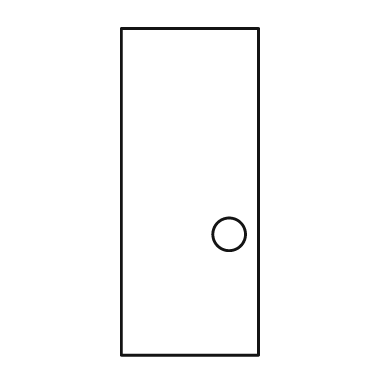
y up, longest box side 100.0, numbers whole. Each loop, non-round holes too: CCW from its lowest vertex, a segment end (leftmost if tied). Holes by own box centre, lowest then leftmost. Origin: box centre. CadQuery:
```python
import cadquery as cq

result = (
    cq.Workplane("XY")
    .moveTo(-21.0, -50.0)
    .lineTo(21.0, -50.0)
    .lineTo(21.0, 50.0)
    .lineTo(-21.0, 50.0)
    .close()
    .moveTo(12.0, -13.0)
    .circle(5.0)
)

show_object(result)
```